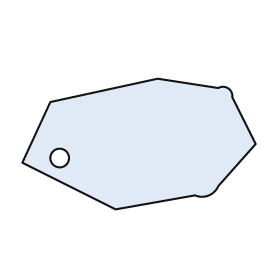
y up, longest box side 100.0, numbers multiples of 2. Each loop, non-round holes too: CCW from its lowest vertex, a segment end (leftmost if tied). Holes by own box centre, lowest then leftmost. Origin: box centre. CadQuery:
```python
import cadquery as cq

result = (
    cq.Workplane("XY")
    .moveTo(-10.0, -28.0)
    .lineTo(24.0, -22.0)
    .threePointArc((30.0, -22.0), (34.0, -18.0))
    .lineTo(50.0, 0.0)
    .lineTo(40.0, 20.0)
    .threePointArc((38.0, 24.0), (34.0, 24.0))
    .lineTo(8.0, 28.0)
    .lineTo(-38.0, 18.0)
    .lineTo(-50.0, -8.0)
    .close()
    .moveTo(-34.0, -6.0)
    .circle(4.0)
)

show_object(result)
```